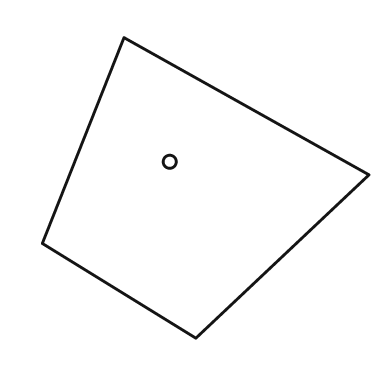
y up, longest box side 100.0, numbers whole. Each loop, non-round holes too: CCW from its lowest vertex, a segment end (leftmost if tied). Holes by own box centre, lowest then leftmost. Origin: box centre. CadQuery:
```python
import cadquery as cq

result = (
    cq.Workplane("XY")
    .moveTo(-3.0, -46.0)
    .lineTo(50.0, 4.0)
    .lineTo(-25.0, 46.0)
    .lineTo(-50.0, -17.0)
    .close()
    .moveTo(-11.0, 8.0)
    .circle(2.0)
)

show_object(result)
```